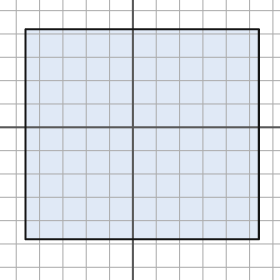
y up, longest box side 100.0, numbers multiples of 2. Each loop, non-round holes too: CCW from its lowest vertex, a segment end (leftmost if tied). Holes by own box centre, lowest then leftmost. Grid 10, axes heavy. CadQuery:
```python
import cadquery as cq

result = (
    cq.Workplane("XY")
    .moveTo(-46.0, -48.0)
    .lineTo(54.0, -48.0)
    .lineTo(54.0, 42.0)
    .lineTo(-46.0, 42.0)
    .close()
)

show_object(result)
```